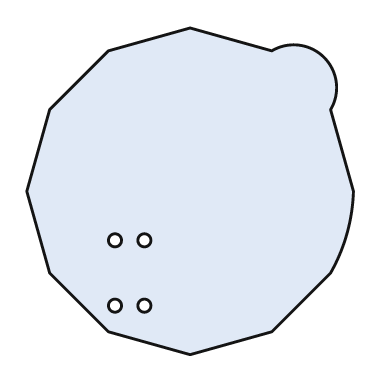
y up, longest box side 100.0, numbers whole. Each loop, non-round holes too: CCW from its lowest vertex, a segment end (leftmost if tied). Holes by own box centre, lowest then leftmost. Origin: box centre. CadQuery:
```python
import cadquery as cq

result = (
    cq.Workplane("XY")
    .moveTo(0.0, -50.0)
    .lineTo(25.0, -43.0)
    .lineTo(43.0, -25.0)
    .threePointArc((48.0, -13.0), (50.0, 0.0))
    .lineTo(43.0, 25.0)
    .threePointArc((41.0, 41.0), (25.0, 43.0))
    .lineTo(0.0, 50.0)
    .lineTo(-25.0, 43.0)
    .lineTo(-43.0, 25.0)
    .lineTo(-50.0, 0.0)
    .lineTo(-43.0, -25.0)
    .lineTo(-25.0, -43.0)
    .close()
    .moveTo(-23.0, -35.0)
    .circle(2.0)
    .moveTo(-14.0, -35.0)
    .circle(2.0)
    .moveTo(-23.0, -15.0)
    .circle(2.0)
    .moveTo(-14.0, -15.0)
    .circle(2.0)
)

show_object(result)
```